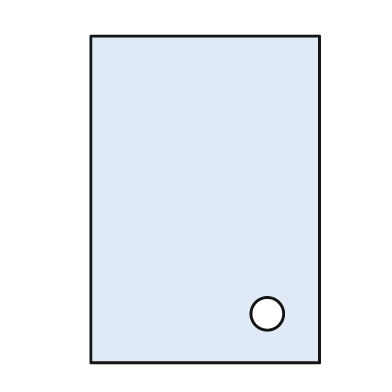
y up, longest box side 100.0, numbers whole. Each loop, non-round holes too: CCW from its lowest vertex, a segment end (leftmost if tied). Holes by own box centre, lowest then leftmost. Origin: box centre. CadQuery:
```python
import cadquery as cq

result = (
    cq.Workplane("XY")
    .moveTo(-35.0, -50.0)
    .lineTo(35.0, -50.0)
    .lineTo(35.0, 50.0)
    .lineTo(-35.0, 50.0)
    .close()
    .moveTo(19.0, -35.0)
    .circle(5.0)
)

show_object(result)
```